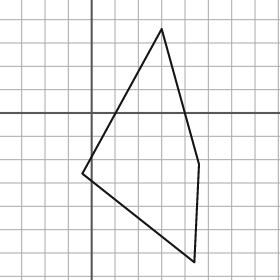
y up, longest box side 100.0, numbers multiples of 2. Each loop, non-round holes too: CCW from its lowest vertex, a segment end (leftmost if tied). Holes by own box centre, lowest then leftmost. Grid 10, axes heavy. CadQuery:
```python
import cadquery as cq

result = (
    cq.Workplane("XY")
    .moveTo(44.0, -64.0)
    .lineTo(46.0, -22.0)
    .lineTo(30.0, 36.0)
    .lineTo(-4.0, -26.0)
    .close()
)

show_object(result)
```